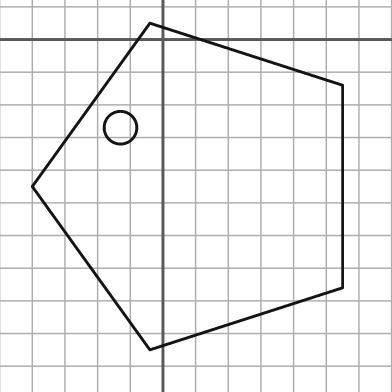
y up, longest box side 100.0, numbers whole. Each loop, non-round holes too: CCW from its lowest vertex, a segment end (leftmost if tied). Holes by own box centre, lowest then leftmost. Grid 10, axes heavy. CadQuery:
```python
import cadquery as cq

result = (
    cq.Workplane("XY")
    .moveTo(-4.0, -95.0)
    .lineTo(55.0, -76.0)
    .lineTo(55.0, -14.0)
    .lineTo(-4.0, 5.0)
    .lineTo(-40.0, -45.0)
    .close()
    .moveTo(-13.0, -27.0)
    .circle(5.0)
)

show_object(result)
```